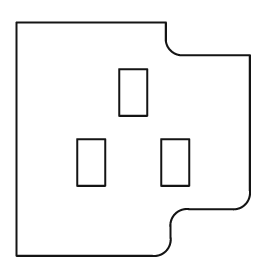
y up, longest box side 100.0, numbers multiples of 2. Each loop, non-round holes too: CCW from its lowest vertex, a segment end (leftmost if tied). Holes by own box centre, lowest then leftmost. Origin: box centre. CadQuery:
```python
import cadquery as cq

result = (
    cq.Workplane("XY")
    .moveTo(-50.0, -50.0)
    .lineTo(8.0, -50.0)
    .threePointArc((14.0, -48.0), (16.0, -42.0))
    .lineTo(16.0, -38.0)
    .threePointArc((18.0, -32.0), (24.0, -30.0))
    .lineTo(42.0, -30.0)
    .threePointArc((48.0, -28.0), (50.0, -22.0))
    .lineTo(50.0, 36.0)
    .lineTo(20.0, 36.0)
    .threePointArc((16.0, 38.0), (14.0, 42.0))
    .lineTo(14.0, 50.0)
    .lineTo(-50.0, 50.0)
    .close()
    .moveTo(-24.0, -20.0)
    .lineTo(-12.0, -20.0)
    .lineTo(-12.0, 0.0)
    .lineTo(-24.0, 0.0)
    .close()
    .moveTo(12.0, -20.0)
    .lineTo(24.0, -20.0)
    .lineTo(24.0, 0.0)
    .lineTo(12.0, 0.0)
    .close()
    .moveTo(-6.0, 10.0)
    .lineTo(6.0, 10.0)
    .lineTo(6.0, 30.0)
    .lineTo(-6.0, 30.0)
    .close()
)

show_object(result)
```